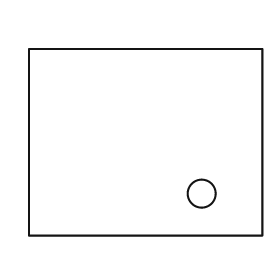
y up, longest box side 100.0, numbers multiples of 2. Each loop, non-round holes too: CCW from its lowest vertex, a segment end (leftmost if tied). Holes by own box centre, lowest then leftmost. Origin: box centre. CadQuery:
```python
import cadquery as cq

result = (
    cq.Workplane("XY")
    .moveTo(-50.0, -40.0)
    .lineTo(50.0, -40.0)
    .lineTo(50.0, 40.0)
    .lineTo(-50.0, 40.0)
    .close()
    .moveTo(24.0, -22.0)
    .circle(6.0)
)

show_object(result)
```